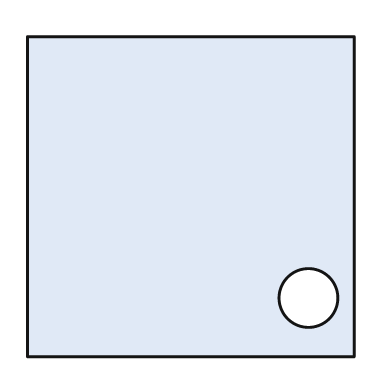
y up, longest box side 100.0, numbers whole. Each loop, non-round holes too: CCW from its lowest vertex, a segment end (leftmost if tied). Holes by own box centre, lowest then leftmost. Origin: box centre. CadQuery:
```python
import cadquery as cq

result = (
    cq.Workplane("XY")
    .moveTo(-50.0, -49.0)
    .lineTo(50.0, -49.0)
    .lineTo(50.0, 49.0)
    .lineTo(-50.0, 49.0)
    .close()
    .moveTo(36.0, -31.0)
    .circle(9.0)
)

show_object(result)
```